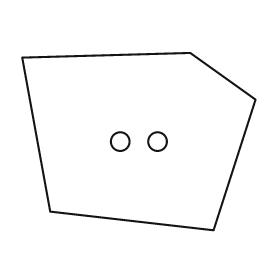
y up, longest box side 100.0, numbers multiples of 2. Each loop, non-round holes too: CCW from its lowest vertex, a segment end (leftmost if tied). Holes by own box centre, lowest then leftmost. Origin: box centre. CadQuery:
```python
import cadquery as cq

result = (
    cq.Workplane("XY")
    .moveTo(32.0, -38.0)
    .lineTo(50.0, 18.0)
    .lineTo(22.0, 38.0)
    .lineTo(-50.0, 36.0)
    .lineTo(-38.0, -30.0)
    .close()
    .moveTo(-8.0, 0.0)
    .circle(4.0)
    .moveTo(8.0, 0.0)
    .circle(4.0)
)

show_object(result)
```